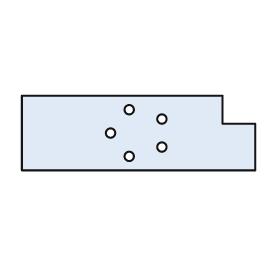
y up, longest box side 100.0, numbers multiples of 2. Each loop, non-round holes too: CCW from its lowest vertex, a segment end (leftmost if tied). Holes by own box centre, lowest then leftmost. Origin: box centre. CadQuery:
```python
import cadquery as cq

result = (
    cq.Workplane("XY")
    .moveTo(-50.0, -16.0)
    .lineTo(50.0, -16.0)
    .lineTo(50.0, 4.0)
    .lineTo(36.0, 4.0)
    .lineTo(36.0, 16.0)
    .lineTo(-50.0, 16.0)
    .close()
    .moveTo(-4.0, -10.0)
    .circle(2.0)
    .moveTo(10.0, -6.0)
    .circle(2.0)
    .moveTo(-12.0, 0.0)
    .circle(2.0)
    .moveTo(10.0, 6.0)
    .circle(2.0)
    .moveTo(-4.0, 10.0)
    .circle(2.0)
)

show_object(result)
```